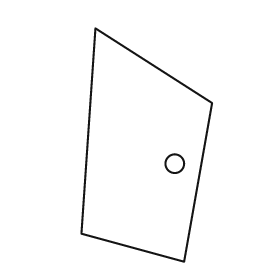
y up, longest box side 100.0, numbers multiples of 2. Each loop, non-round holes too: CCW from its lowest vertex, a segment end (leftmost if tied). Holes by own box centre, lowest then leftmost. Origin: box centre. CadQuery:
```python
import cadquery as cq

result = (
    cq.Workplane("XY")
    .moveTo(16.0, -50.0)
    .lineTo(28.0, 18.0)
    .lineTo(-22.0, 50.0)
    .lineTo(-28.0, -38.0)
    .close()
    .moveTo(12.0, -8.0)
    .circle(4.0)
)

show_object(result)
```